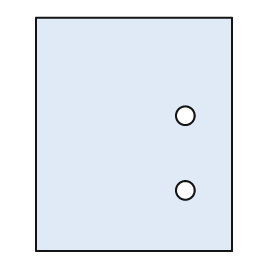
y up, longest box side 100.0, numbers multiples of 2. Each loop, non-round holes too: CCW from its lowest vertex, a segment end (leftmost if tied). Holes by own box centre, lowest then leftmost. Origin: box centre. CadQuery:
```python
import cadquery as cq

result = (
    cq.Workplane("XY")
    .moveTo(-42.0, -50.0)
    .lineTo(42.0, -50.0)
    .lineTo(42.0, 50.0)
    .lineTo(-42.0, 50.0)
    .close()
    .moveTo(22.0, -24.0)
    .circle(4.0)
    .moveTo(22.0, 8.0)
    .circle(4.0)
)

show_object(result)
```